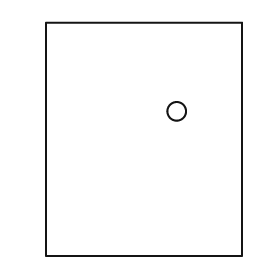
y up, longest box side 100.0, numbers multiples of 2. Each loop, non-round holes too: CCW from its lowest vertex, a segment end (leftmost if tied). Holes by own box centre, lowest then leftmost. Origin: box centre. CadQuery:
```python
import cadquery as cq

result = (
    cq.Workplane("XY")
    .moveTo(-42.0, -50.0)
    .lineTo(42.0, -50.0)
    .lineTo(42.0, 50.0)
    .lineTo(-42.0, 50.0)
    .close()
    .moveTo(14.0, 12.0)
    .circle(4.0)
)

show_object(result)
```